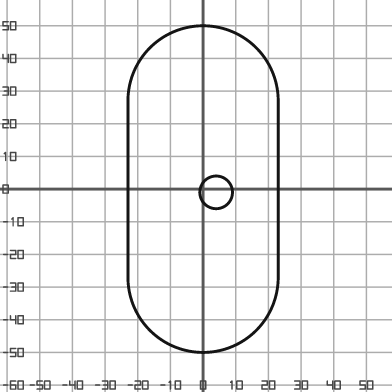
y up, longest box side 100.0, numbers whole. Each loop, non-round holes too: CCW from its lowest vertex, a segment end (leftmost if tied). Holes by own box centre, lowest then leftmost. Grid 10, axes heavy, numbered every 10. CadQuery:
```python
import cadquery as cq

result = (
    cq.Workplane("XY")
    .moveTo(-23.0, -27.0)
    .threePointArc((0.0, -50.0), (23.0, -27.0))
    .lineTo(23.0, 27.0)
    .threePointArc((0.0, 50.0), (-23.0, 27.0))
    .close()
    .moveTo(4.0, -1.0)
    .circle(5.0)
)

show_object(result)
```